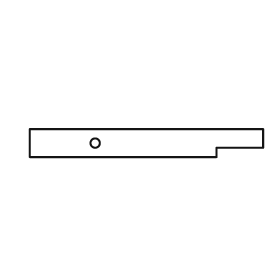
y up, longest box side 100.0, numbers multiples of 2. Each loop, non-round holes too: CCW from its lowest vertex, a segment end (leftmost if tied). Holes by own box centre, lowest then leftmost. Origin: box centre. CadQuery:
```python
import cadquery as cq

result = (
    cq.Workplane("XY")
    .moveTo(-50.0, -6.0)
    .lineTo(30.0, -6.0)
    .lineTo(30.0, -2.0)
    .lineTo(50.0, -2.0)
    .lineTo(50.0, 6.0)
    .lineTo(-50.0, 6.0)
    .close()
    .moveTo(-22.0, 0.0)
    .circle(2.0)
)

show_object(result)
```